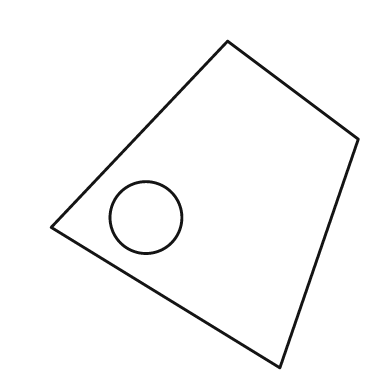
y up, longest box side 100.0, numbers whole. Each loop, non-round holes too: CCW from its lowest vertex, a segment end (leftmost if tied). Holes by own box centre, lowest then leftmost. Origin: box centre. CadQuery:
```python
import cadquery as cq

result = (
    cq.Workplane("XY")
    .moveTo(23.0, -50.0)
    .lineTo(47.0, 20.0)
    .lineTo(7.0, 50.0)
    .lineTo(-47.0, -7.0)
    .close()
    .moveTo(-18.0, -4.0)
    .circle(11.0)
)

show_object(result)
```